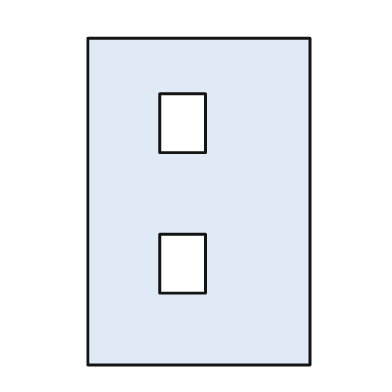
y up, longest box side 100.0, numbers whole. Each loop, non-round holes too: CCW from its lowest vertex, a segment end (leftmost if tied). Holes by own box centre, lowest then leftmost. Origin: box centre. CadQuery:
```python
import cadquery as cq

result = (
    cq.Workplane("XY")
    .moveTo(-34.0, -50.0)
    .lineTo(34.0, -50.0)
    .lineTo(34.0, 50.0)
    .lineTo(-34.0, 50.0)
    .close()
    .moveTo(-12.0, -28.0)
    .lineTo(2.0, -28.0)
    .lineTo(2.0, -10.0)
    .lineTo(-12.0, -10.0)
    .close()
    .moveTo(-12.0, 15.0)
    .lineTo(2.0, 15.0)
    .lineTo(2.0, 33.0)
    .lineTo(-12.0, 33.0)
    .close()
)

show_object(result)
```